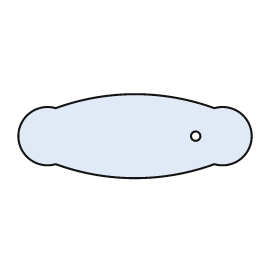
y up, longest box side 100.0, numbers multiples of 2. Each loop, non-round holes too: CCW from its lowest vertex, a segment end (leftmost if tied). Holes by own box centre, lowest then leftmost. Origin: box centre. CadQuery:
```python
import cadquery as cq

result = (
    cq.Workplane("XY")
    .moveTo(-34.0, -12.0)
    .threePointArc((0.0, -18.0), (34.0, -12.0))
    .threePointArc((50.0, 0.0), (34.0, 12.0))
    .threePointArc((0.0, 18.0), (-34.0, 12.0))
    .threePointArc((-50.0, 0.0), (-34.0, -12.0))
    .close()
    .moveTo(26.0, 0.0)
    .circle(2.0)
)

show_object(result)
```